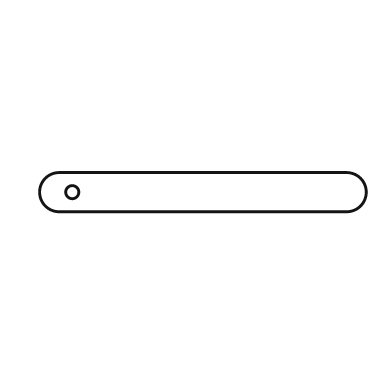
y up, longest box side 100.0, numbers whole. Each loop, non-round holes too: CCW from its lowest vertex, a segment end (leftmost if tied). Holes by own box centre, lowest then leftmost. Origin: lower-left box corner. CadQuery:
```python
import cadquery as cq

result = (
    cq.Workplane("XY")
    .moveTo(6.0, 0.0)
    .lineTo(94.0, 0.0)
    .threePointArc((100.0, 6.0), (94.0, 12.0))
    .lineTo(6.0, 12.0)
    .threePointArc((0.0, 6.0), (6.0, 0.0))
    .close()
    .moveTo(10.0, 6.0)
    .circle(2.0)
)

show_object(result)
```